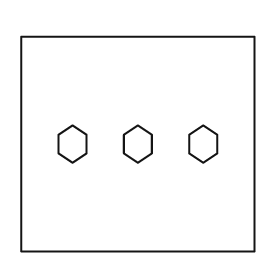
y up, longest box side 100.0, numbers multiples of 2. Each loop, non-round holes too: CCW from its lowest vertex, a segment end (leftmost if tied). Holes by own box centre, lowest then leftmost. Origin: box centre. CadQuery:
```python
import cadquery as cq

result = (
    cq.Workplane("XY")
    .moveTo(-50.0, -46.0)
    .lineTo(50.0, -46.0)
    .lineTo(50.0, 46.0)
    .lineTo(-50.0, 46.0)
    .close()
    .moveTo(-28.0, -8.0)
    .lineTo(-22.0, -4.0)
    .lineTo(-22.0, 4.0)
    .lineTo(-28.0, 8.0)
    .lineTo(-34.0, 4.0)
    .lineTo(-34.0, -4.0)
    .close()
    .moveTo(0.0, -8.0)
    .lineTo(6.0, -4.0)
    .lineTo(6.0, 4.0)
    .lineTo(0.0, 8.0)
    .lineTo(-6.0, 4.0)
    .lineTo(-6.0, -4.0)
    .close()
    .moveTo(28.0, -8.0)
    .lineTo(34.0, -4.0)
    .lineTo(34.0, 4.0)
    .lineTo(28.0, 8.0)
    .lineTo(22.0, 4.0)
    .lineTo(22.0, -4.0)
    .close()
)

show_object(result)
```